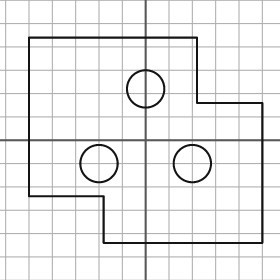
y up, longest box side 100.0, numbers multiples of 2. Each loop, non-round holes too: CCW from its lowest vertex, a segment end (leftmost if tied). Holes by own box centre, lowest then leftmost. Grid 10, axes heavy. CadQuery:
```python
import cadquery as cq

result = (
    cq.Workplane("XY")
    .moveTo(-18.0, -44.0)
    .lineTo(50.0, -44.0)
    .lineTo(50.0, 16.0)
    .lineTo(22.0, 16.0)
    .lineTo(22.0, 44.0)
    .lineTo(-50.0, 44.0)
    .lineTo(-50.0, -24.0)
    .lineTo(-18.0, -24.0)
    .close()
    .moveTo(-20.0, -10.0)
    .circle(8.0)
    .moveTo(20.0, -10.0)
    .circle(8.0)
    .moveTo(0.0, 22.0)
    .circle(8.0)
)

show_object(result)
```